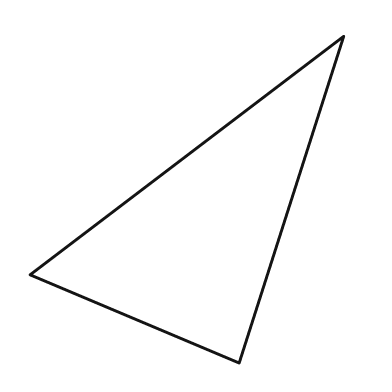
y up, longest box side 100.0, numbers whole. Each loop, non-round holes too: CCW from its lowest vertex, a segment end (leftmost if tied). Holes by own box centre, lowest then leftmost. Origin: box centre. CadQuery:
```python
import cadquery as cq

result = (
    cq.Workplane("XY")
    .moveTo(16.0, -50.0)
    .lineTo(48.0, 50.0)
    .lineTo(-48.0, -23.0)
    .close()
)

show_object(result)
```